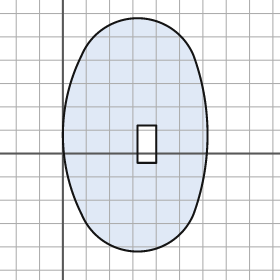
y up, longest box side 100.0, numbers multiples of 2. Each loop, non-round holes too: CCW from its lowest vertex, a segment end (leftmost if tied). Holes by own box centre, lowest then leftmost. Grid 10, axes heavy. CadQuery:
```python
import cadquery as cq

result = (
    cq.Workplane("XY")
    .moveTo(8.0, -26.0)
    .threePointArc((32.0, -42.0), (56.0, -26.0))
    .threePointArc((62.0, 8.0), (56.0, 42.0))
    .threePointArc((32.0, 58.0), (8.0, 42.0))
    .threePointArc((0.0, 8.0), (8.0, -26.0))
    .close()
    .moveTo(32.0, -4.0)
    .lineTo(40.0, -4.0)
    .lineTo(40.0, 12.0)
    .lineTo(32.0, 12.0)
    .close()
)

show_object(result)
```